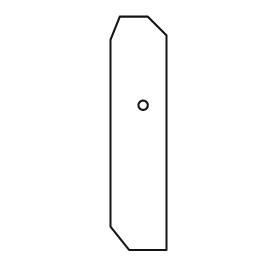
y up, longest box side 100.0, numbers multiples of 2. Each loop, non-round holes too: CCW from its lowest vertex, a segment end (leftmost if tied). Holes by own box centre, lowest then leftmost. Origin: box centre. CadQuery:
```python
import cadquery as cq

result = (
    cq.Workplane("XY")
    .moveTo(-4.0, -50.0)
    .lineTo(12.0, -50.0)
    .lineTo(12.0, 42.0)
    .lineTo(4.0, 50.0)
    .lineTo(-8.0, 50.0)
    .lineTo(-12.0, 40.0)
    .lineTo(-12.0, -40.0)
    .close()
    .moveTo(2.0, 12.0)
    .circle(2.0)
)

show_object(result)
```